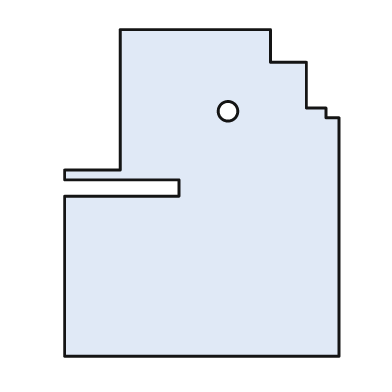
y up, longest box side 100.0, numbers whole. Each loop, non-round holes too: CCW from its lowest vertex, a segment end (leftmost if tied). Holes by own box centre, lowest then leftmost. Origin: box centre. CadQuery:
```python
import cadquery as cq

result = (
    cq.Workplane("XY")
    .moveTo(-42.0, -50.0)
    .lineTo(42.0, -50.0)
    .lineTo(42.0, 23.0)
    .lineTo(38.0, 23.0)
    .lineTo(38.0, 26.0)
    .lineTo(32.0, 26.0)
    .lineTo(32.0, 40.0)
    .lineTo(21.0, 40.0)
    .lineTo(21.0, 50.0)
    .lineTo(-25.0, 50.0)
    .lineTo(-25.0, 7.0)
    .lineTo(-42.0, 7.0)
    .lineTo(-42.0, 4.0)
    .lineTo(-7.0, 4.0)
    .lineTo(-7.0, -1.0)
    .lineTo(-42.0, -1.0)
    .close()
    .moveTo(8.0, 25.0)
    .circle(3.0)
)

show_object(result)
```